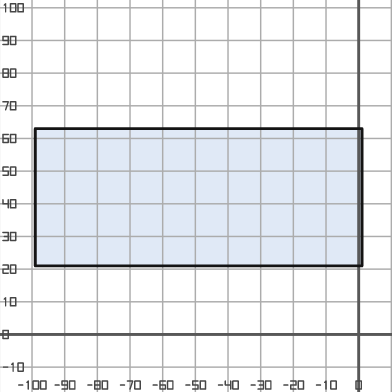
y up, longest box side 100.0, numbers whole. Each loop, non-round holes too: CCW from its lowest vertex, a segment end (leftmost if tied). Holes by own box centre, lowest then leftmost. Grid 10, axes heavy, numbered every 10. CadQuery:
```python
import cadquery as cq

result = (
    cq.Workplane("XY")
    .moveTo(-99.0, 21.0)
    .lineTo(1.0, 21.0)
    .lineTo(1.0, 63.0)
    .lineTo(-99.0, 63.0)
    .close()
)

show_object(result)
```